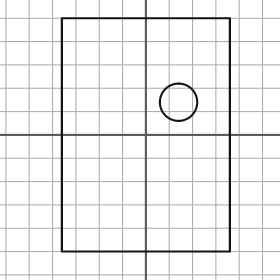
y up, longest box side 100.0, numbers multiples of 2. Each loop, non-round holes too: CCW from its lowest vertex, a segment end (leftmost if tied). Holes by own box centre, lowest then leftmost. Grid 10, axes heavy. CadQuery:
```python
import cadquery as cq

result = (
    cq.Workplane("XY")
    .moveTo(-36.0, -50.0)
    .lineTo(36.0, -50.0)
    .lineTo(36.0, 50.0)
    .lineTo(-36.0, 50.0)
    .close()
    .moveTo(14.0, 14.0)
    .circle(8.0)
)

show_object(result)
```